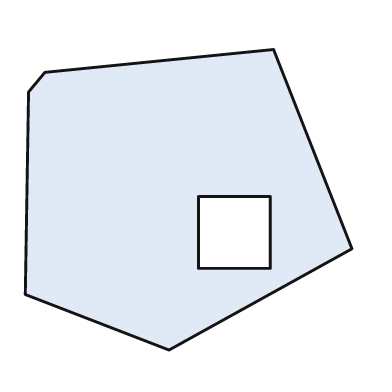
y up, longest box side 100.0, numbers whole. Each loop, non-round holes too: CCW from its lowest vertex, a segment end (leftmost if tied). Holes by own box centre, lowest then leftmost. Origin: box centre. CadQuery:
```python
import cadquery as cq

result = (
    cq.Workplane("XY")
    .moveTo(-6.0, -46.0)
    .lineTo(50.0, -15.0)
    .lineTo(26.0, 46.0)
    .lineTo(-44.0, 39.0)
    .lineTo(-49.0, 33.0)
    .lineTo(-50.0, -29.0)
    .close()
    .moveTo(3.0, -21.0)
    .lineTo(25.0, -21.0)
    .lineTo(25.0, 1.0)
    .lineTo(3.0, 1.0)
    .close()
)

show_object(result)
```